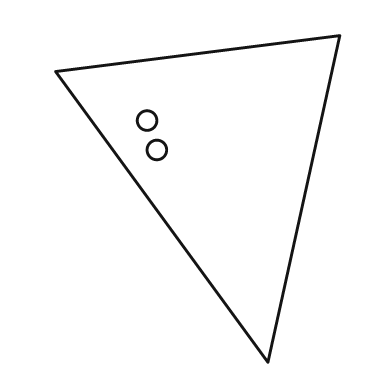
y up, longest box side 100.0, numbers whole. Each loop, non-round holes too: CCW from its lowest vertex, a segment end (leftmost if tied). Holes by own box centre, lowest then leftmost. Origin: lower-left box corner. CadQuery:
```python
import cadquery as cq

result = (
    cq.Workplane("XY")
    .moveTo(65.0, 0.0)
    .lineTo(87.0, 100.0)
    .lineTo(0.0, 89.0)
    .close()
    .moveTo(31.0, 65.0)
    .circle(3.0)
    .moveTo(28.0, 74.0)
    .circle(3.0)
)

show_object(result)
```